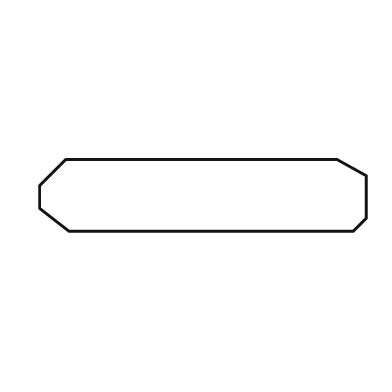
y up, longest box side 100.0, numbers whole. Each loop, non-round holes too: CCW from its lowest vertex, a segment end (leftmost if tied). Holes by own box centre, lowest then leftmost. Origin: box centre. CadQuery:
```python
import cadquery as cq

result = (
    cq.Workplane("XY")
    .moveTo(-41.0, -11.0)
    .lineTo(46.0, -11.0)
    .lineTo(50.0, -7.0)
    .lineTo(50.0, 6.0)
    .lineTo(41.0, 11.0)
    .lineTo(-42.0, 11.0)
    .lineTo(-50.0, 3.0)
    .lineTo(-50.0, -4.0)
    .close()
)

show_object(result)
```